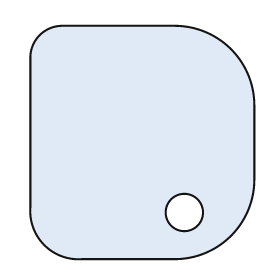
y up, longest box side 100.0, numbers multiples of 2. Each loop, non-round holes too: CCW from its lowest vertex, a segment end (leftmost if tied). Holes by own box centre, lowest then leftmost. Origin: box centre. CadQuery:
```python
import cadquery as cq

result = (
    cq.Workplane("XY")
    .moveTo(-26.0, -50.0)
    .lineTo(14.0, -50.0)
    .threePointArc((38.0, -40.0), (48.0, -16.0))
    .lineTo(48.0, 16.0)
    .threePointArc((38.0, 40.0), (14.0, 50.0))
    .lineTo(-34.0, 50.0)
    .threePointArc((-44.0, 46.0), (-48.0, 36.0))
    .lineTo(-48.0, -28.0)
    .threePointArc((-42.0, -44.0), (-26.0, -50.0))
    .close()
    .moveTo(18.0, -30.0)
    .circle(8.0)
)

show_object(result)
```